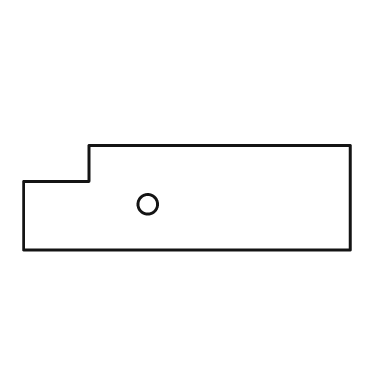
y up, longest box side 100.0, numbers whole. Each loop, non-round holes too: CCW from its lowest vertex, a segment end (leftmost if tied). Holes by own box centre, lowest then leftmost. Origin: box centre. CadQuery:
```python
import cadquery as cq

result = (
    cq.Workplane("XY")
    .moveTo(-50.0, -16.0)
    .lineTo(50.0, -16.0)
    .lineTo(50.0, 16.0)
    .lineTo(-30.0, 16.0)
    .lineTo(-30.0, 5.0)
    .lineTo(-50.0, 5.0)
    .close()
    .moveTo(-12.0, -2.0)
    .circle(3.0)
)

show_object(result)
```